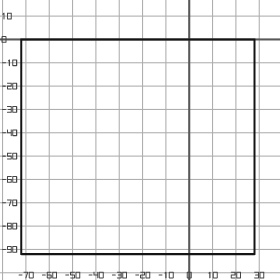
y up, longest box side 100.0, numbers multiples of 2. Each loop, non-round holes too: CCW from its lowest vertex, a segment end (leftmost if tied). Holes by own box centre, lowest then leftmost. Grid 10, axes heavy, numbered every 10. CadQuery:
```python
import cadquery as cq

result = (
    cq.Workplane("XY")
    .moveTo(-72.0, -92.0)
    .lineTo(28.0, -92.0)
    .lineTo(28.0, 0.0)
    .lineTo(-72.0, 0.0)
    .close()
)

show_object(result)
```